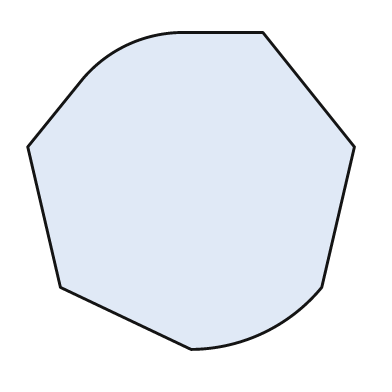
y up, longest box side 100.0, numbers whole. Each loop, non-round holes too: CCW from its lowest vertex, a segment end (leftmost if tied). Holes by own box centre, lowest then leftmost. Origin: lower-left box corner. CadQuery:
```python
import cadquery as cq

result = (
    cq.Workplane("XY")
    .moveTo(50.0, 0.0)
    .threePointArc((72.0, 5.0), (90.0, 19.0))
    .lineTo(100.0, 62.0)
    .lineTo(72.0, 97.0)
    .lineTo(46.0, 97.0)
    .threePointArc((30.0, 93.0), (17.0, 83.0))
    .lineTo(0.0, 62.0)
    .lineTo(10.0, 19.0)
    .close()
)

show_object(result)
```